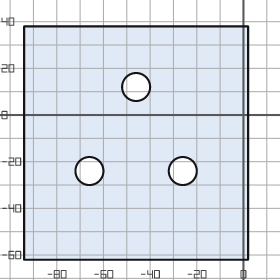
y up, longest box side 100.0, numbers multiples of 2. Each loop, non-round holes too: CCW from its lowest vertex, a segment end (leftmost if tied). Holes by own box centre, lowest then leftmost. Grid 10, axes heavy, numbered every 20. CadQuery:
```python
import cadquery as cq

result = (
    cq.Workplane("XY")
    .moveTo(-94.0, -62.0)
    .lineTo(2.0, -62.0)
    .lineTo(2.0, 38.0)
    .lineTo(-94.0, 38.0)
    .close()
    .moveTo(-66.0, -24.0)
    .circle(6.0)
    .moveTo(-26.0, -24.0)
    .circle(6.0)
    .moveTo(-46.0, 12.0)
    .circle(6.0)
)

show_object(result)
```